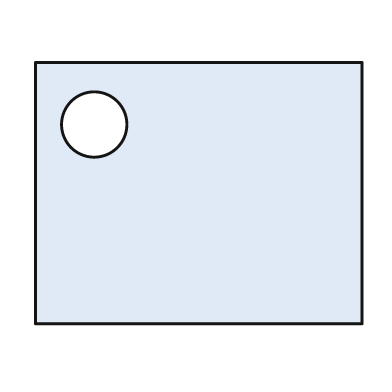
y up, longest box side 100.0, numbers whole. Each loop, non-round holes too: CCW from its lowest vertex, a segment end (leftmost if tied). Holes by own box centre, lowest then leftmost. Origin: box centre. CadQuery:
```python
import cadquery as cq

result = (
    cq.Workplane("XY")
    .moveTo(-50.0, -40.0)
    .lineTo(50.0, -40.0)
    .lineTo(50.0, 40.0)
    .lineTo(-50.0, 40.0)
    .close()
    .moveTo(-32.0, 21.0)
    .circle(10.0)
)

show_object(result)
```